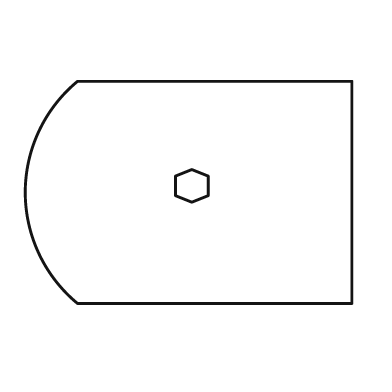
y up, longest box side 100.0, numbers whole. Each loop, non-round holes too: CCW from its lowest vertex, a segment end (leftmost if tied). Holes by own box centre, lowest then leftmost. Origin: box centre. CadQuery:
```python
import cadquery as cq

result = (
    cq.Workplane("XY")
    .moveTo(-34.0, -34.0)
    .lineTo(50.0, -34.0)
    .lineTo(50.0, 34.0)
    .lineTo(-34.0, 34.0)
    .threePointArc((-50.0, 0.0), (-34.0, -34.0))
    .close()
    .moveTo(1.0, -3.0)
    .lineTo(6.0, -1.0)
    .lineTo(6.0, 5.0)
    .lineTo(1.0, 7.0)
    .lineTo(-4.0, 5.0)
    .lineTo(-4.0, -1.0)
    .close()
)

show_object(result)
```